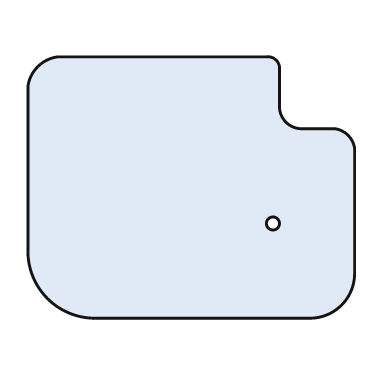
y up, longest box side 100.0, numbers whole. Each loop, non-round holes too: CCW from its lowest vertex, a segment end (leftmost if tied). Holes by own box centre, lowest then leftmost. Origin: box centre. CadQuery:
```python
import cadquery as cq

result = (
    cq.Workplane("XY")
    .moveTo(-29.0, -40.0)
    .lineTo(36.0, -40.0)
    .threePointArc((46.0, -36.0), (50.0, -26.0))
    .lineTo(50.0, 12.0)
    .threePointArc((48.0, 16.0), (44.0, 18.0))
    .lineTo(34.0, 18.0)
    .threePointArc((29.0, 20.0), (27.0, 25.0))
    .lineTo(27.0, 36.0)
    .threePointArc((26.0, 39.0), (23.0, 40.0))
    .lineTo(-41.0, 40.0)
    .threePointArc((-47.0, 37.0), (-50.0, 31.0))
    .lineTo(-50.0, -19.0)
    .threePointArc((-44.0, -34.0), (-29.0, -40.0))
    .close()
    .moveTo(25.0, -11.0)
    .circle(2.0)
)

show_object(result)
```